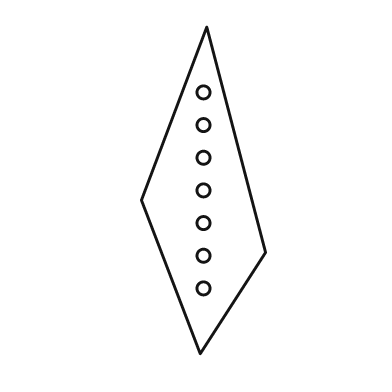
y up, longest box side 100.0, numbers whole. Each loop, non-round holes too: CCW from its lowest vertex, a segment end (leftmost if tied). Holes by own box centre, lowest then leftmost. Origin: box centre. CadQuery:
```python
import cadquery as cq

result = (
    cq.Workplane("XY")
    .moveTo(-1.0, -50.0)
    .lineTo(19.0, -19.0)
    .lineTo(1.0, 50.0)
    .lineTo(-19.0, -3.0)
    .close()
    .moveTo(0.0, -30.0)
    .circle(2.0)
    .moveTo(0.0, -20.0)
    .circle(2.0)
    .moveTo(0.0, -10.0)
    .circle(2.0)
    .moveTo(0.0, 0.0)
    .circle(2.0)
    .moveTo(0.0, 10.0)
    .circle(2.0)
    .moveTo(0.0, 20.0)
    .circle(2.0)
    .moveTo(0.0, 30.0)
    .circle(2.0)
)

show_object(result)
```